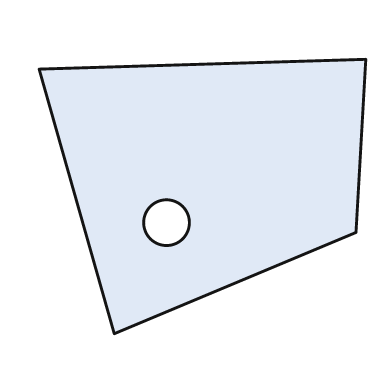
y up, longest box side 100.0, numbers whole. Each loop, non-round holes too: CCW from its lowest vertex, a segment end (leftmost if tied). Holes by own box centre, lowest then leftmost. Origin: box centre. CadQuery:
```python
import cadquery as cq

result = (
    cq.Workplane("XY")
    .moveTo(-27.0, -42.0)
    .lineTo(47.0, -11.0)
    .lineTo(50.0, 42.0)
    .lineTo(-50.0, 39.0)
    .close()
    .moveTo(-11.0, -8.0)
    .circle(7.0)
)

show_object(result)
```